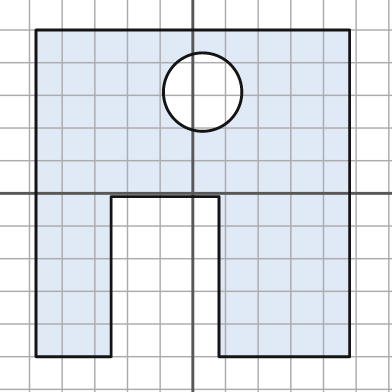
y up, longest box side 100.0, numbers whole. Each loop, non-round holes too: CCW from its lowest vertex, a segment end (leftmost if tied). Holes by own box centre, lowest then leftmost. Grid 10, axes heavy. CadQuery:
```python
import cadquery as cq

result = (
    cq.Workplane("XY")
    .moveTo(-48.0, -50.0)
    .lineTo(-25.0, -50.0)
    .lineTo(-25.0, -1.0)
    .lineTo(8.0, -1.0)
    .lineTo(8.0, -50.0)
    .lineTo(48.0, -50.0)
    .lineTo(48.0, 50.0)
    .lineTo(-48.0, 50.0)
    .close()
    .moveTo(3.0, 31.0)
    .circle(12.0)
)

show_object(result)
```